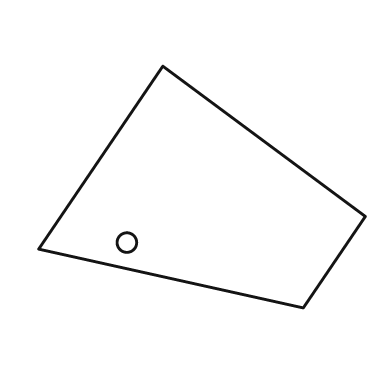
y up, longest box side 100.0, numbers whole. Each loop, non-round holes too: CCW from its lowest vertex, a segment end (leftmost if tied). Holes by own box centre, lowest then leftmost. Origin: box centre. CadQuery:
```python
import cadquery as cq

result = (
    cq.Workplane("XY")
    .moveTo(31.0, -37.0)
    .lineTo(50.0, -9.0)
    .lineTo(-12.0, 37.0)
    .lineTo(-50.0, -19.0)
    .close()
    .moveTo(-23.0, -17.0)
    .circle(3.0)
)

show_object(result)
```